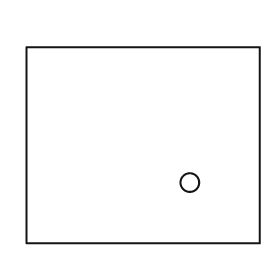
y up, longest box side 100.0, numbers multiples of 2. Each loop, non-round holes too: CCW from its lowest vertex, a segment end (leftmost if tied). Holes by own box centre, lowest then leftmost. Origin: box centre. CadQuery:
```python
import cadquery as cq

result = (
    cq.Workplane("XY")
    .moveTo(-50.0, -42.0)
    .lineTo(50.0, -42.0)
    .lineTo(50.0, 42.0)
    .lineTo(-50.0, 42.0)
    .close()
    .moveTo(20.0, -16.0)
    .circle(4.0)
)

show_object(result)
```